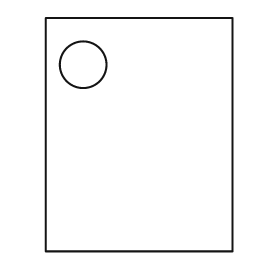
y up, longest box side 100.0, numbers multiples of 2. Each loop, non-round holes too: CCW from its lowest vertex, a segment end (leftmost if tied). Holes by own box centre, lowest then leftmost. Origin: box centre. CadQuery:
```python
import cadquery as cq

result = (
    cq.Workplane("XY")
    .moveTo(-40.0, -50.0)
    .lineTo(40.0, -50.0)
    .lineTo(40.0, 50.0)
    .lineTo(-40.0, 50.0)
    .close()
    .moveTo(-24.0, 30.0)
    .circle(10.0)
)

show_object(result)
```